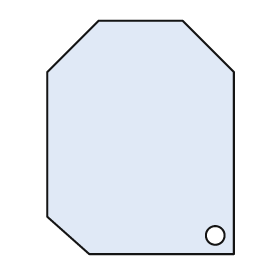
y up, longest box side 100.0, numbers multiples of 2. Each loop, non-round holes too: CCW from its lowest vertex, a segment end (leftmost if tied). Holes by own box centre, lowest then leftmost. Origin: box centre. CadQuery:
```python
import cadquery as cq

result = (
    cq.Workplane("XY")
    .moveTo(-22.0, -50.0)
    .lineTo(40.0, -50.0)
    .lineTo(40.0, 28.0)
    .lineTo(18.0, 50.0)
    .lineTo(-18.0, 50.0)
    .lineTo(-40.0, 28.0)
    .lineTo(-40.0, -34.0)
    .close()
    .moveTo(32.0, -42.0)
    .circle(4.0)
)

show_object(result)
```